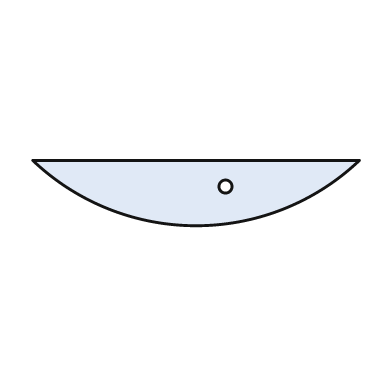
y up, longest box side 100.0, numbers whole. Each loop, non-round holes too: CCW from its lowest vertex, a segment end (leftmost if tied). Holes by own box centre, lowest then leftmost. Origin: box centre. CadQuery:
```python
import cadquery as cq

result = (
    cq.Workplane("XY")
    .moveTo(-50.0, 10.0)
    .threePointArc((0.0, -10.0), (50.0, 10.0))
    .close()
    .moveTo(9.0, 2.0)
    .circle(2.0)
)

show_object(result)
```